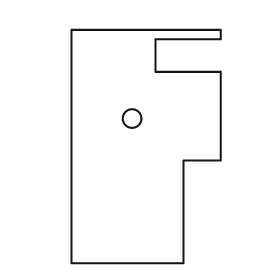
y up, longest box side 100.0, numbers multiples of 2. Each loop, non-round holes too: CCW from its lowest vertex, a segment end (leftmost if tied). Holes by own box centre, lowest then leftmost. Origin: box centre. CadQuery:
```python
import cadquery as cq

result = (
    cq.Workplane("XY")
    .moveTo(-32.0, -50.0)
    .lineTo(16.0, -50.0)
    .lineTo(16.0, -6.0)
    .lineTo(32.0, -6.0)
    .lineTo(32.0, 32.0)
    .lineTo(4.0, 32.0)
    .lineTo(4.0, 46.0)
    .lineTo(32.0, 46.0)
    .lineTo(32.0, 50.0)
    .lineTo(-32.0, 50.0)
    .close()
    .moveTo(-6.0, 12.0)
    .circle(4.0)
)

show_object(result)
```